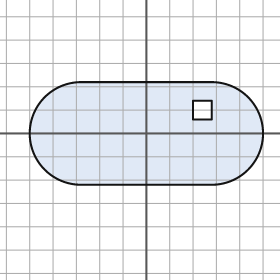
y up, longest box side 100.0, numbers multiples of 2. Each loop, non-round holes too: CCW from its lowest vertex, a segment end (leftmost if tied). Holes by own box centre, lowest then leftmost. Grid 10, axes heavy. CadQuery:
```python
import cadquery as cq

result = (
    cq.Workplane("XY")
    .moveTo(-28.0, -22.0)
    .lineTo(28.0, -22.0)
    .threePointArc((50.0, 0.0), (28.0, 22.0))
    .lineTo(-28.0, 22.0)
    .threePointArc((-50.0, 0.0), (-28.0, -22.0))
    .close()
    .moveTo(20.0, 6.0)
    .lineTo(28.0, 6.0)
    .lineTo(28.0, 14.0)
    .lineTo(20.0, 14.0)
    .close()
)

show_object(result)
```